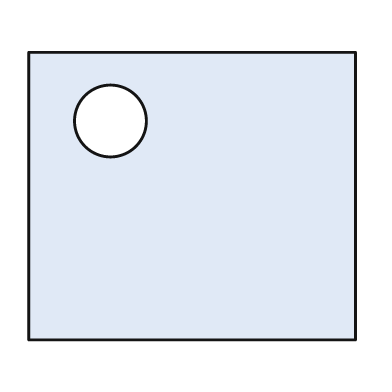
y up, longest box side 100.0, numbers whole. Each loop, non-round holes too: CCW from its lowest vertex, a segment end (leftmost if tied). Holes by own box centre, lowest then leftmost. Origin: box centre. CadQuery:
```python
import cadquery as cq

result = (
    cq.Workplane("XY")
    .moveTo(-50.0, -44.0)
    .lineTo(50.0, -44.0)
    .lineTo(50.0, 44.0)
    .lineTo(-50.0, 44.0)
    .close()
    .moveTo(-25.0, 23.0)
    .circle(11.0)
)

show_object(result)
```